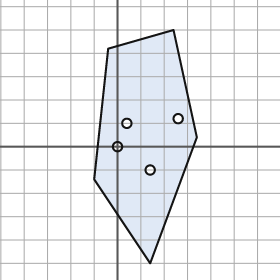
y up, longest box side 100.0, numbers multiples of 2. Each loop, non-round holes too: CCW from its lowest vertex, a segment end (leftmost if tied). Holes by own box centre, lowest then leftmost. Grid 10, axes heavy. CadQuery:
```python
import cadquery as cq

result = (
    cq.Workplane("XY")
    .moveTo(14.0, -50.0)
    .lineTo(34.0, 4.0)
    .lineTo(24.0, 50.0)
    .lineTo(-4.0, 42.0)
    .lineTo(-10.0, -14.0)
    .close()
    .moveTo(14.0, -10.0)
    .circle(2.0)
    .moveTo(0.0, 0.0)
    .circle(2.0)
    .moveTo(4.0, 10.0)
    .circle(2.0)
    .moveTo(26.0, 12.0)
    .circle(2.0)
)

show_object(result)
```